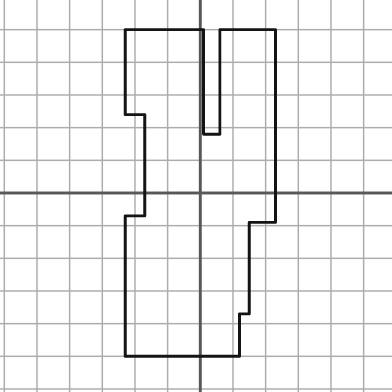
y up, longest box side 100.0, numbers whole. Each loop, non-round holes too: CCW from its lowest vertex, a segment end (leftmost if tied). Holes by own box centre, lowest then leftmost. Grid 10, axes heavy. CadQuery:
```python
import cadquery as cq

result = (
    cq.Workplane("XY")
    .moveTo(-23.0, -50.0)
    .lineTo(12.0, -50.0)
    .lineTo(12.0, -37.0)
    .lineTo(15.0, -37.0)
    .lineTo(15.0, -9.0)
    .lineTo(23.0, -9.0)
    .lineTo(23.0, 50.0)
    .lineTo(6.0, 50.0)
    .lineTo(6.0, 18.0)
    .lineTo(1.0, 18.0)
    .lineTo(1.0, 50.0)
    .lineTo(-23.0, 50.0)
    .lineTo(-23.0, 24.0)
    .lineTo(-17.0, 24.0)
    .lineTo(-17.0, -7.0)
    .lineTo(-23.0, -7.0)
    .close()
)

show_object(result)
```